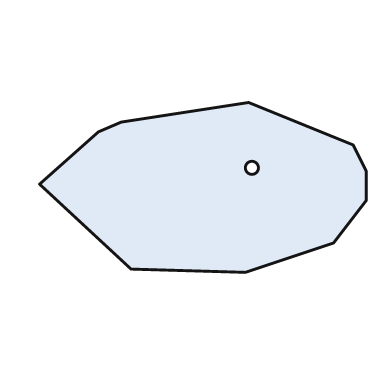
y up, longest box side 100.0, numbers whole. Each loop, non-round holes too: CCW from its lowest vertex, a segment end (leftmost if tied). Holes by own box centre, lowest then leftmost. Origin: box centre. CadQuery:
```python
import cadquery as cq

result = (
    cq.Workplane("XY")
    .moveTo(13.0, -26.0)
    .lineTo(40.0, -17.0)
    .lineTo(50.0, -4.0)
    .lineTo(50.0, 5.0)
    .lineTo(46.0, 13.0)
    .lineTo(14.0, 26.0)
    .lineTo(-25.0, 20.0)
    .lineTo(-32.0, 17.0)
    .lineTo(-50.0, 1.0)
    .lineTo(-22.0, -25.0)
    .close()
    .moveTo(15.0, 6.0)
    .circle(2.0)
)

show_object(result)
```